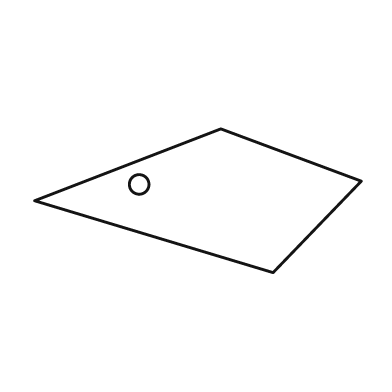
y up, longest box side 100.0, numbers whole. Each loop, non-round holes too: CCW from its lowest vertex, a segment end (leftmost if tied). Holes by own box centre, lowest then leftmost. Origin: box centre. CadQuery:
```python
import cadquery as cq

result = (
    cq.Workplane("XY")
    .moveTo(23.0, -22.0)
    .lineTo(50.0, 6.0)
    .lineTo(7.0, 22.0)
    .lineTo(-50.0, 0.0)
    .close()
    .moveTo(-18.0, 5.0)
    .circle(3.0)
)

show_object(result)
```